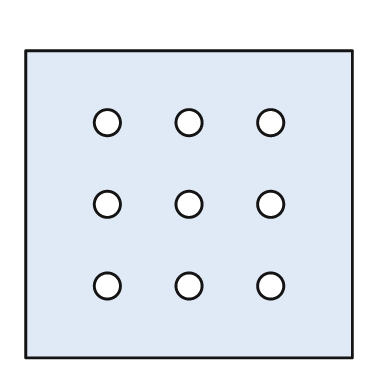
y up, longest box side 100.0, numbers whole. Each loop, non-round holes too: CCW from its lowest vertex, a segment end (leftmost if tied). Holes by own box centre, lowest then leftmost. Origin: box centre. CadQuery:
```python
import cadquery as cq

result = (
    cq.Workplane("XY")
    .moveTo(-50.0, -47.0)
    .lineTo(50.0, -47.0)
    .lineTo(50.0, 47.0)
    .lineTo(-50.0, 47.0)
    .close()
    .moveTo(-25.0, -25.0)
    .circle(4.0)
    .moveTo(0.0, -25.0)
    .circle(4.0)
    .moveTo(25.0, -25.0)
    .circle(4.0)
    .moveTo(-25.0, 0.0)
    .circle(4.0)
    .moveTo(0.0, 0.0)
    .circle(4.0)
    .moveTo(25.0, 0.0)
    .circle(4.0)
    .moveTo(-25.0, 25.0)
    .circle(4.0)
    .moveTo(0.0, 25.0)
    .circle(4.0)
    .moveTo(25.0, 25.0)
    .circle(4.0)
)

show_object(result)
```